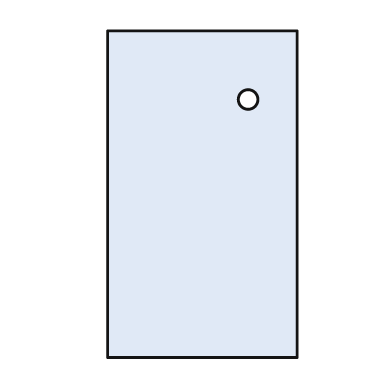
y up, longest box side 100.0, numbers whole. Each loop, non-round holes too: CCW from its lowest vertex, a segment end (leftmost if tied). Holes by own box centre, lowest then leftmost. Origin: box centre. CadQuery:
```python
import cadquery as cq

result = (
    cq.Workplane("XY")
    .moveTo(-29.0, -50.0)
    .lineTo(29.0, -50.0)
    .lineTo(29.0, 50.0)
    .lineTo(-29.0, 50.0)
    .close()
    .moveTo(14.0, 29.0)
    .circle(3.0)
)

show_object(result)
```